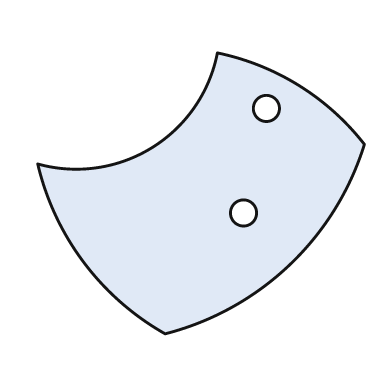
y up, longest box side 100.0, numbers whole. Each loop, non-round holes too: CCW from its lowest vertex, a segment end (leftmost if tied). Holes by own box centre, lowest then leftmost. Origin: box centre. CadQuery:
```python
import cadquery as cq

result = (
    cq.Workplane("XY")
    .moveTo(-11.0, -43.0)
    .threePointArc((27.0, -22.0), (50.0, 15.0))
    .threePointArc((30.0, 33.0), (5.0, 43.0))
    .threePointArc((-15.0, 14.0), (-50.0, 9.0))
    .threePointArc((-36.0, -21.0), (-11.0, -43.0))
    .close()
    .moveTo(13.0, -6.0)
    .circle(4.0)
    .moveTo(20.0, 26.0)
    .circle(4.0)
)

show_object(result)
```